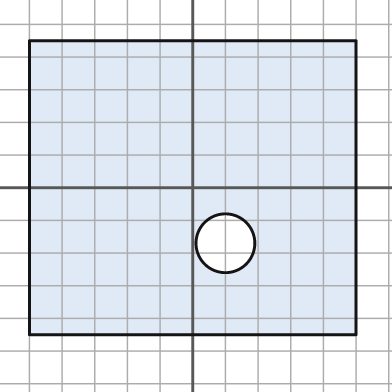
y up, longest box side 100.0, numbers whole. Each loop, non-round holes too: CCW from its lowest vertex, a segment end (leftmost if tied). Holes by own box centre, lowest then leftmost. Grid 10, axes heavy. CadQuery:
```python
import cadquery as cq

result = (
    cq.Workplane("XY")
    .moveTo(-50.0, -45.0)
    .lineTo(50.0, -45.0)
    .lineTo(50.0, 45.0)
    .lineTo(-50.0, 45.0)
    .close()
    .moveTo(10.0, -17.0)
    .circle(9.0)
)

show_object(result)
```